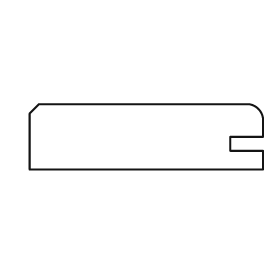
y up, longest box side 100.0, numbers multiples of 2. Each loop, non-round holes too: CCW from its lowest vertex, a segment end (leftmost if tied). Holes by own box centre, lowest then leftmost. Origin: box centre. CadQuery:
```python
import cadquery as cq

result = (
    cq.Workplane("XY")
    .moveTo(-50.0, -14.0)
    .lineTo(50.0, -14.0)
    .lineTo(50.0, -6.0)
    .lineTo(36.0, -6.0)
    .lineTo(36.0, 0.0)
    .lineTo(50.0, 0.0)
    .lineTo(50.0, 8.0)
    .threePointArc((48.0, 12.0), (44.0, 14.0))
    .lineTo(-46.0, 14.0)
    .lineTo(-50.0, 10.0)
    .close()
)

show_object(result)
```